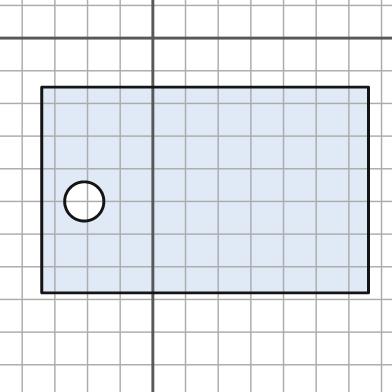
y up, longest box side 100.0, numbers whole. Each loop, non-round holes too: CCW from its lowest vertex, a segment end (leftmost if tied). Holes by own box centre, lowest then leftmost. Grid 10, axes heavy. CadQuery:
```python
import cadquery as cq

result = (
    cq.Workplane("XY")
    .moveTo(-34.0, -78.0)
    .lineTo(66.0, -78.0)
    .lineTo(66.0, -15.0)
    .lineTo(-34.0, -15.0)
    .close()
    .moveTo(-21.0, -50.0)
    .circle(6.0)
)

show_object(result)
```